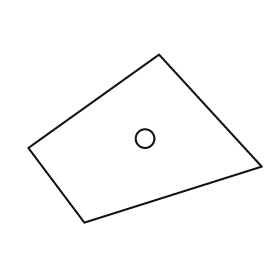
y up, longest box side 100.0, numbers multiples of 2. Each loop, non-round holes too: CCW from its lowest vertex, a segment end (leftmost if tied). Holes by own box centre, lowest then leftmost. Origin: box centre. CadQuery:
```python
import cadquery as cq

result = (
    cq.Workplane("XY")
    .moveTo(-26.0, -36.0)
    .lineTo(50.0, -12.0)
    .lineTo(6.0, 36.0)
    .lineTo(-50.0, -4.0)
    .close()
    .moveTo(0.0, 0.0)
    .circle(4.0)
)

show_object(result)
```